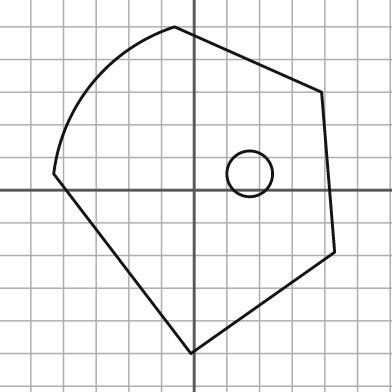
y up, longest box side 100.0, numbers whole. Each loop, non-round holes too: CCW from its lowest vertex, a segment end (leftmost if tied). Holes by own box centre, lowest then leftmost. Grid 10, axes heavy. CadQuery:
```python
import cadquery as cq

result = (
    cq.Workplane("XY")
    .moveTo(-1.0, -50.0)
    .lineTo(43.0, -19.0)
    .lineTo(39.0, 30.0)
    .lineTo(-6.0, 50.0)
    .threePointArc((-31.0, 33.0), (-43.0, 5.0))
    .close()
    .moveTo(17.0, 5.0)
    .circle(7.0)
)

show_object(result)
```